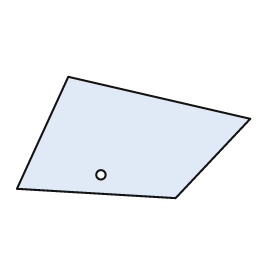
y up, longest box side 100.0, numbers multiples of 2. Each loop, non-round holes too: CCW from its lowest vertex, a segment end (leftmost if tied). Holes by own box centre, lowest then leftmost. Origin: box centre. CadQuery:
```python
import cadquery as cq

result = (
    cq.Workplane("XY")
    .moveTo(18.0, -26.0)
    .lineTo(50.0, 8.0)
    .lineTo(-28.0, 26.0)
    .lineTo(-50.0, -22.0)
    .close()
    .moveTo(-14.0, -16.0)
    .circle(2.0)
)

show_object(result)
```